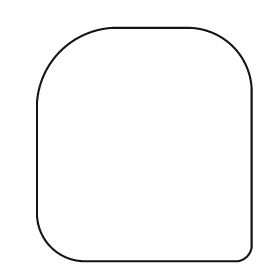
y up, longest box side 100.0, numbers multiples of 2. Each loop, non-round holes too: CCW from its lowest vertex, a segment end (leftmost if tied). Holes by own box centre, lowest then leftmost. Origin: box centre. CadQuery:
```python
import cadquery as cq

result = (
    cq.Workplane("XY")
    .moveTo(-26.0, -50.0)
    .lineTo(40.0, -50.0)
    .threePointArc((44.0, -48.0), (46.0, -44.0))
    .lineTo(46.0, 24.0)
    .threePointArc((38.0, 42.0), (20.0, 50.0))
    .lineTo(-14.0, 50.0)
    .threePointArc((-36.0, 40.0), (-46.0, 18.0))
    .lineTo(-46.0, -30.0)
    .threePointArc((-40.0, -44.0), (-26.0, -50.0))
    .close()
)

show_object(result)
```